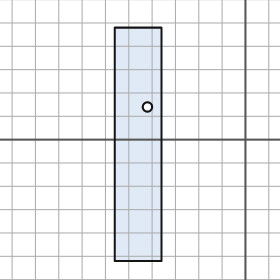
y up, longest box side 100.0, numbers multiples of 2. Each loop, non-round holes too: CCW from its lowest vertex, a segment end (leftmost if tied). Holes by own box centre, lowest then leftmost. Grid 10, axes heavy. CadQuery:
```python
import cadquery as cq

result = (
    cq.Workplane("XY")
    .moveTo(-56.0, -52.0)
    .lineTo(-36.0, -52.0)
    .lineTo(-36.0, 48.0)
    .lineTo(-56.0, 48.0)
    .close()
    .moveTo(-42.0, 14.0)
    .circle(2.0)
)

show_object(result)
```